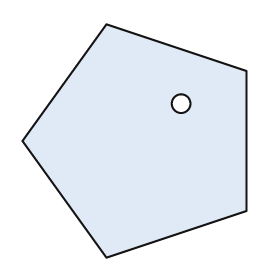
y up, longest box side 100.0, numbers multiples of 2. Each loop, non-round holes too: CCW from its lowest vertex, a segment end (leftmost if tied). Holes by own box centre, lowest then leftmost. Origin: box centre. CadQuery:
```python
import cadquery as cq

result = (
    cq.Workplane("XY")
    .moveTo(-12.0, -50.0)
    .lineTo(48.0, -30.0)
    .lineTo(48.0, 30.0)
    .lineTo(-12.0, 50.0)
    .lineTo(-48.0, 0.0)
    .close()
    .moveTo(20.0, 16.0)
    .circle(4.0)
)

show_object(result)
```